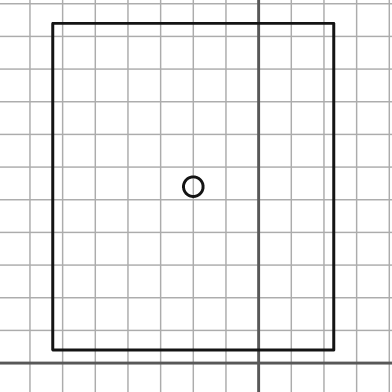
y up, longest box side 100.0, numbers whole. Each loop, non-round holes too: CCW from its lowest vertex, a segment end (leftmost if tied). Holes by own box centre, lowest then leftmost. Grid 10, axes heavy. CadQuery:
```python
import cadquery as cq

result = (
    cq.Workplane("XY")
    .moveTo(-63.0, 4.0)
    .lineTo(23.0, 4.0)
    .lineTo(23.0, 104.0)
    .lineTo(-63.0, 104.0)
    .close()
    .moveTo(-20.0, 54.0)
    .circle(3.0)
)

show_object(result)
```